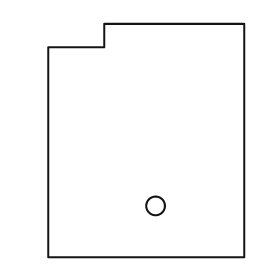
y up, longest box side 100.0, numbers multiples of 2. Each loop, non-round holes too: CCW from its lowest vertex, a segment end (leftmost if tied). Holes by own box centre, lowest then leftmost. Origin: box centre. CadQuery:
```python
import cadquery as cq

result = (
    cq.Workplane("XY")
    .moveTo(-42.0, -50.0)
    .lineTo(42.0, -50.0)
    .lineTo(42.0, 50.0)
    .lineTo(-18.0, 50.0)
    .lineTo(-18.0, 40.0)
    .lineTo(-42.0, 40.0)
    .close()
    .moveTo(4.0, -28.0)
    .circle(4.0)
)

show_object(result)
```